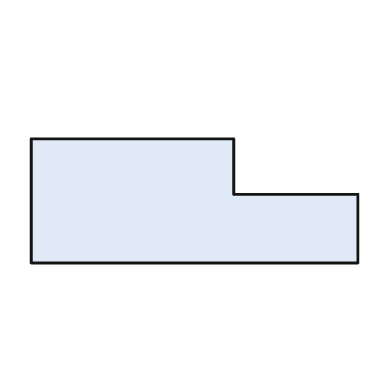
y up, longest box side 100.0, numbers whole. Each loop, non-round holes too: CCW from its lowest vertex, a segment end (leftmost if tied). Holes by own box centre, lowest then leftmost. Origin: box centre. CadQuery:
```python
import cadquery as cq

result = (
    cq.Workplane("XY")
    .moveTo(-50.0, -19.0)
    .lineTo(50.0, -19.0)
    .lineTo(50.0, 2.0)
    .lineTo(12.0, 2.0)
    .lineTo(12.0, 19.0)
    .lineTo(-50.0, 19.0)
    .close()
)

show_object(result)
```